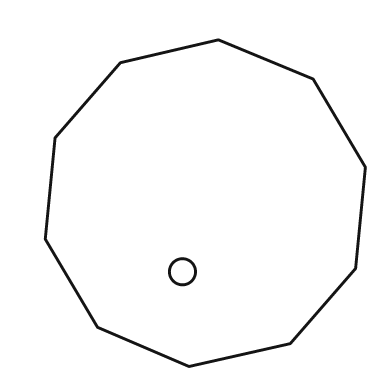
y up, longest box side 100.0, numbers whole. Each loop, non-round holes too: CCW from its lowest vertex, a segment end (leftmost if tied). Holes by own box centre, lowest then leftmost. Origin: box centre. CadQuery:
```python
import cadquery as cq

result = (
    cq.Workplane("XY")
    .moveTo(-5.0, -50.0)
    .lineTo(26.0, -43.0)
    .lineTo(46.0, -20.0)
    .lineTo(49.0, 11.0)
    .lineTo(33.0, 38.0)
    .lineTo(4.0, 50.0)
    .lineTo(-26.0, 43.0)
    .lineTo(-46.0, 20.0)
    .lineTo(-49.0, -11.0)
    .lineTo(-33.0, -38.0)
    .close()
    .moveTo(-7.0, -21.0)
    .circle(4.0)
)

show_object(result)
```